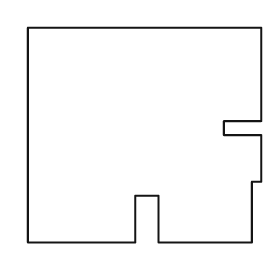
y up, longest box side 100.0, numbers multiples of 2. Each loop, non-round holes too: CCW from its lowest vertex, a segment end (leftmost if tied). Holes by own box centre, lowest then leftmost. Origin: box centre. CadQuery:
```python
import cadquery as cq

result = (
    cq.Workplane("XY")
    .moveTo(-50.0, -46.0)
    .lineTo(-4.0, -46.0)
    .lineTo(-4.0, -26.0)
    .lineTo(6.0, -26.0)
    .lineTo(6.0, -46.0)
    .lineTo(46.0, -46.0)
    .lineTo(46.0, -20.0)
    .lineTo(50.0, -20.0)
    .lineTo(50.0, 0.0)
    .lineTo(34.0, 0.0)
    .lineTo(34.0, 6.0)
    .lineTo(50.0, 6.0)
    .lineTo(50.0, 46.0)
    .lineTo(-50.0, 46.0)
    .close()
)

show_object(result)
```